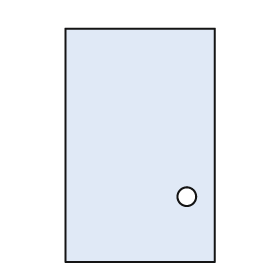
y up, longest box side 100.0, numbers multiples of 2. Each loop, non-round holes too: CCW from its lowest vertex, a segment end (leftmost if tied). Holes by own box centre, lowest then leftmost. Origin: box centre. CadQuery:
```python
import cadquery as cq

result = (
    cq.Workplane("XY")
    .moveTo(-32.0, -50.0)
    .lineTo(32.0, -50.0)
    .lineTo(32.0, 50.0)
    .lineTo(-32.0, 50.0)
    .close()
    .moveTo(20.0, -22.0)
    .circle(4.0)
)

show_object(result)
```